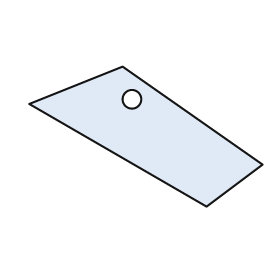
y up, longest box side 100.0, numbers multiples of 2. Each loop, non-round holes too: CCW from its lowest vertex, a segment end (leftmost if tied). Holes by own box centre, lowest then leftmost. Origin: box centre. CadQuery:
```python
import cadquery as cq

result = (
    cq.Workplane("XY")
    .moveTo(26.0, -30.0)
    .lineTo(50.0, -12.0)
    .lineTo(-10.0, 30.0)
    .lineTo(-50.0, 14.0)
    .close()
    .moveTo(-6.0, 16.0)
    .circle(4.0)
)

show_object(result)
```